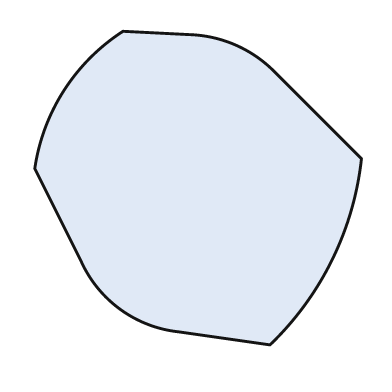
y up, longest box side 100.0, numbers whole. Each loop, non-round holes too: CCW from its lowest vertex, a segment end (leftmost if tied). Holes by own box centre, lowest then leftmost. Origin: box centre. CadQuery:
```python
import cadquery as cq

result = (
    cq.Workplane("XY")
    .moveTo(22.0, -48.0)
    .threePointArc((41.0, -22.0), (50.0, 9.0))
    .lineTo(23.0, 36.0)
    .threePointArc((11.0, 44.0), (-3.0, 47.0))
    .lineTo(-23.0, 48.0)
    .threePointArc((-41.0, 30.0), (-50.0, 6.0))
    .lineTo(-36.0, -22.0)
    .threePointArc((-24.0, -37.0), (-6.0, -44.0))
    .close()
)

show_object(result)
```